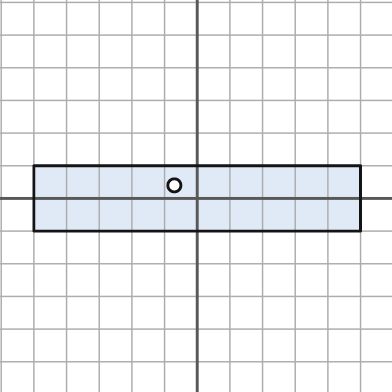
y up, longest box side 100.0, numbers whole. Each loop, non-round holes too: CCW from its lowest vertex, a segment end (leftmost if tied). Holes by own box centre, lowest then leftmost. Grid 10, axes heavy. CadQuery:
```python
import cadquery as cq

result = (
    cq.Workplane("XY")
    .moveTo(-50.0, -10.0)
    .lineTo(50.0, -10.0)
    .lineTo(50.0, 10.0)
    .lineTo(-50.0, 10.0)
    .close()
    .moveTo(-7.0, 4.0)
    .circle(2.0)
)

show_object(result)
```